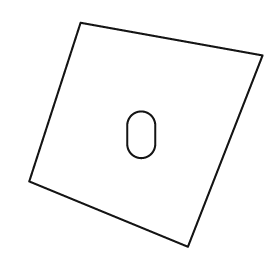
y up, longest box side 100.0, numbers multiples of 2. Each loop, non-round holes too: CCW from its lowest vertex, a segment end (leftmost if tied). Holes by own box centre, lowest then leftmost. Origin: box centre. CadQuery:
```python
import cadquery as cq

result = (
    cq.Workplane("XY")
    .moveTo(18.0, -48.0)
    .lineTo(50.0, 34.0)
    .lineTo(-28.0, 48.0)
    .lineTo(-50.0, -20.0)
    .close()
    .moveTo(-8.0, -4.0)
    .threePointArc((-2.0, -10.0), (4.0, -4.0))
    .lineTo(4.0, 4.0)
    .threePointArc((-2.0, 10.0), (-8.0, 4.0))
    .close()
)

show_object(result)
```